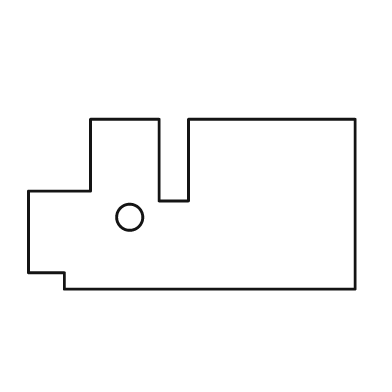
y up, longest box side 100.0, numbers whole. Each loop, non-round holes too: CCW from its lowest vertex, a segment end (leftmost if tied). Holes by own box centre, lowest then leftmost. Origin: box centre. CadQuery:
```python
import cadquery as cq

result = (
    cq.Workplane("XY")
    .moveTo(-39.0, -26.0)
    .lineTo(50.0, -26.0)
    .lineTo(50.0, 26.0)
    .lineTo(-1.0, 26.0)
    .lineTo(-1.0, 1.0)
    .lineTo(-10.0, 1.0)
    .lineTo(-10.0, 26.0)
    .lineTo(-31.0, 26.0)
    .lineTo(-31.0, 4.0)
    .lineTo(-50.0, 4.0)
    .lineTo(-50.0, -21.0)
    .lineTo(-39.0, -21.0)
    .close()
    .moveTo(-19.0, -4.0)
    .circle(4.0)
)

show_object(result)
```